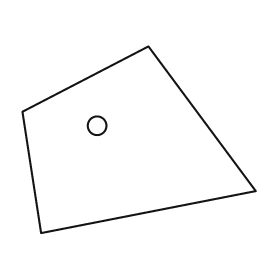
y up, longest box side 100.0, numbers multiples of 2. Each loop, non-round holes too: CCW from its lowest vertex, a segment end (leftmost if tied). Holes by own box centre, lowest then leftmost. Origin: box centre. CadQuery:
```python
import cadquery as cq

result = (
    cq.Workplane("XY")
    .moveTo(-42.0, -40.0)
    .lineTo(50.0, -22.0)
    .lineTo(4.0, 40.0)
    .lineTo(-50.0, 12.0)
    .close()
    .moveTo(-18.0, 6.0)
    .circle(4.0)
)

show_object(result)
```